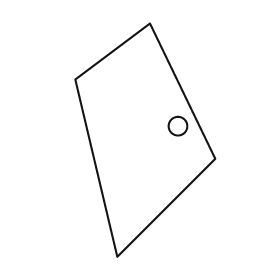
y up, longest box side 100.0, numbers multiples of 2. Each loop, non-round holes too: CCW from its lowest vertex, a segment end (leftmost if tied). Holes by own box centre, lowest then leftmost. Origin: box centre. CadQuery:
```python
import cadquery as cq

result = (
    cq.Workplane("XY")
    .moveTo(-12.0, -50.0)
    .lineTo(30.0, -8.0)
    .lineTo(2.0, 50.0)
    .lineTo(-30.0, 26.0)
    .close()
    .moveTo(14.0, 6.0)
    .circle(4.0)
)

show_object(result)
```